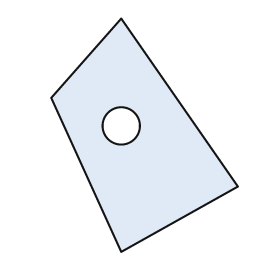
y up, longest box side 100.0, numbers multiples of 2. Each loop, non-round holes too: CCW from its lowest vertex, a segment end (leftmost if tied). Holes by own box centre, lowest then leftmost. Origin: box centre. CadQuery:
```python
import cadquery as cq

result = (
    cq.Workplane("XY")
    .moveTo(-10.0, -50.0)
    .lineTo(40.0, -22.0)
    .lineTo(-10.0, 50.0)
    .lineTo(-40.0, 16.0)
    .close()
    .moveTo(-10.0, 4.0)
    .circle(8.0)
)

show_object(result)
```